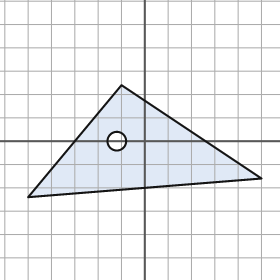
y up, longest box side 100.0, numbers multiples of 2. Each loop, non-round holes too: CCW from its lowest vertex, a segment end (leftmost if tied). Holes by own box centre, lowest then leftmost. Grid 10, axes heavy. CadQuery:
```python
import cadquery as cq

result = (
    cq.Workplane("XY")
    .moveTo(-50.0, -24.0)
    .lineTo(50.0, -16.0)
    .lineTo(-10.0, 24.0)
    .close()
    .moveTo(-12.0, 0.0)
    .circle(4.0)
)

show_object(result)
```